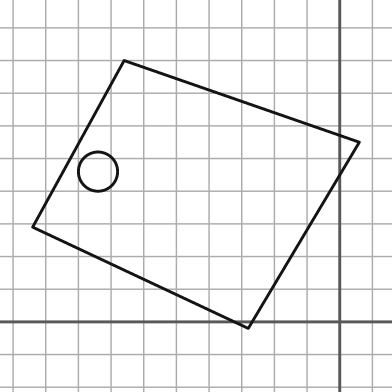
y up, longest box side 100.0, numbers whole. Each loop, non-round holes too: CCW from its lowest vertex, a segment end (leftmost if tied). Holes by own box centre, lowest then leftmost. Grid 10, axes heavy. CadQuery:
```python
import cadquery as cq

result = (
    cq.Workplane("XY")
    .moveTo(-28.0, -2.0)
    .lineTo(6.0, 55.0)
    .lineTo(-66.0, 80.0)
    .lineTo(-94.0, 29.0)
    .close()
    .moveTo(-74.0, 46.0)
    .circle(6.0)
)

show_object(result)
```